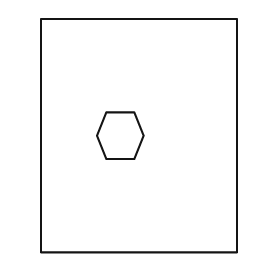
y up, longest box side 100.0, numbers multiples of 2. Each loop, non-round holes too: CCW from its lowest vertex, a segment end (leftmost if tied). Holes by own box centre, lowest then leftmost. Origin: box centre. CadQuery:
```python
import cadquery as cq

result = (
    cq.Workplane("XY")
    .moveTo(-42.0, -50.0)
    .lineTo(42.0, -50.0)
    .lineTo(42.0, 50.0)
    .lineTo(-42.0, 50.0)
    .close()
    .moveTo(-14.0, -10.0)
    .lineTo(-2.0, -10.0)
    .lineTo(2.0, 0.0)
    .lineTo(-2.0, 10.0)
    .lineTo(-14.0, 10.0)
    .lineTo(-18.0, 0.0)
    .close()
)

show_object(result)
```